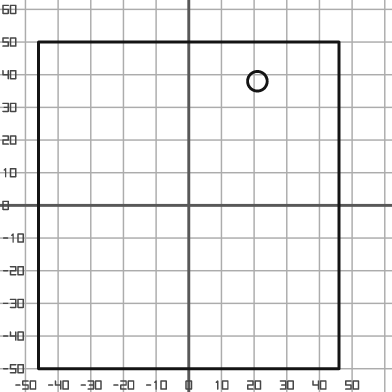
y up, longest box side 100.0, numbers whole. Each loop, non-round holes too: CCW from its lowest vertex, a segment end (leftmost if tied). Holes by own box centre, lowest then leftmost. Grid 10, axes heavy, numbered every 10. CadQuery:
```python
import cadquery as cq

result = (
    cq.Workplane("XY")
    .moveTo(-46.0, -50.0)
    .lineTo(46.0, -50.0)
    .lineTo(46.0, 50.0)
    .lineTo(-46.0, 50.0)
    .close()
    .moveTo(21.0, 38.0)
    .circle(3.0)
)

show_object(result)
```